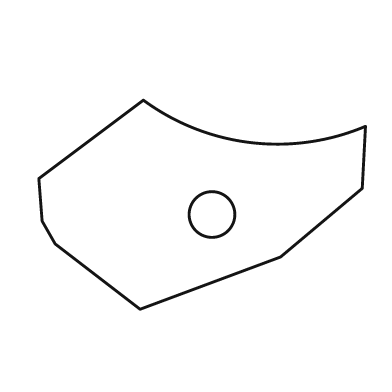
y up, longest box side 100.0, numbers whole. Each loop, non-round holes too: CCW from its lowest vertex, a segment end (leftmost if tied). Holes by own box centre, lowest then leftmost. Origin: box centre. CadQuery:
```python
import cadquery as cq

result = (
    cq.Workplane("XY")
    .moveTo(-19.0, -32.0)
    .lineTo(24.0, -16.0)
    .lineTo(49.0, 5.0)
    .lineTo(50.0, 24.0)
    .threePointArc((15.0, 19.0), (-18.0, 32.0))
    .lineTo(-50.0, 8.0)
    .lineTo(-49.0, -5.0)
    .lineTo(-45.0, -12.0)
    .close()
    .moveTo(3.0, -3.0)
    .circle(7.0)
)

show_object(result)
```